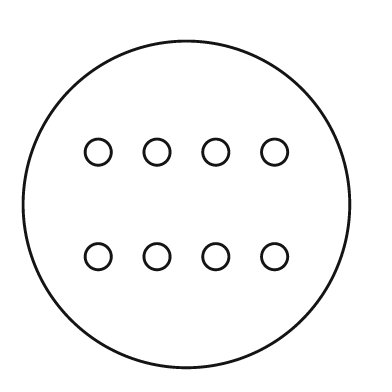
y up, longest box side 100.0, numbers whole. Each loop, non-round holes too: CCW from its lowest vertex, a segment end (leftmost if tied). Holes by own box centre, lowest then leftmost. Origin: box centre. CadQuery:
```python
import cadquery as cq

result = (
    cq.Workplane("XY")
    .moveTo(0.0, 0.0)
    .circle(50.0)
    .moveTo(-27.0, -16.0)
    .circle(4.0)
    .moveTo(-9.0, -16.0)
    .circle(4.0)
    .moveTo(9.0, -16.0)
    .circle(4.0)
    .moveTo(27.0, -16.0)
    .circle(4.0)
    .moveTo(-27.0, 16.0)
    .circle(4.0)
    .moveTo(-9.0, 16.0)
    .circle(4.0)
    .moveTo(9.0, 16.0)
    .circle(4.0)
    .moveTo(27.0, 16.0)
    .circle(4.0)
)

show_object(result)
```